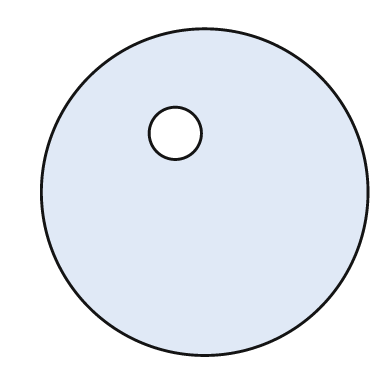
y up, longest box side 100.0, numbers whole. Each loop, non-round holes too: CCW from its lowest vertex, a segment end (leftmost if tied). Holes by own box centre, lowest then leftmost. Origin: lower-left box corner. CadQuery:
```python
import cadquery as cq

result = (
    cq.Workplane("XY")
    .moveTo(50.0, 50.0)
    .circle(50.0)
    .moveTo(41.0, 68.0)
    .circle(8.0)
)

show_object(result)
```